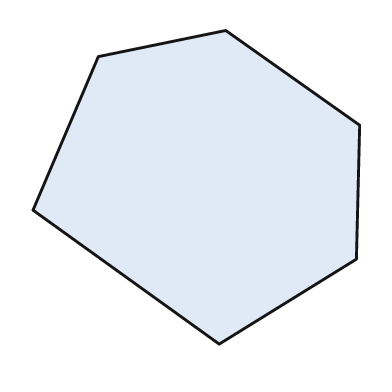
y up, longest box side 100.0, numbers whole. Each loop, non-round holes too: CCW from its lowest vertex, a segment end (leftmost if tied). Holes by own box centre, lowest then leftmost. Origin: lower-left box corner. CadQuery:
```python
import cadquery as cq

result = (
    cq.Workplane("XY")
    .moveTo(57.0, 0.0)
    .lineTo(99.0, 26.0)
    .lineTo(100.0, 67.0)
    .lineTo(59.0, 96.0)
    .lineTo(20.0, 88.0)
    .lineTo(0.0, 41.0)
    .close()
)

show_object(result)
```